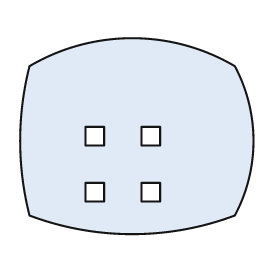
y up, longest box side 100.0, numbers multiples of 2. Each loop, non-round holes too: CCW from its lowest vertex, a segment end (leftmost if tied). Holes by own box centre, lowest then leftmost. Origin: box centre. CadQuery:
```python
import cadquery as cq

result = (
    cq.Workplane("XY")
    .moveTo(-46.0, -34.0)
    .threePointArc((-2.0, -42.0), (42.0, -34.0))
    .threePointArc((50.0, -2.0), (42.0, 30.0))
    .threePointArc((-2.0, 42.0), (-46.0, 30.0))
    .threePointArc((-50.0, -2.0), (-46.0, -34.0))
    .close()
    .moveTo(-22.0, -28.0)
    .lineTo(-14.0, -28.0)
    .lineTo(-14.0, -20.0)
    .lineTo(-22.0, -20.0)
    .close()
    .moveTo(2.0, -28.0)
    .lineTo(10.0, -28.0)
    .lineTo(10.0, -20.0)
    .lineTo(2.0, -20.0)
    .close()
    .moveTo(-22.0, -4.0)
    .lineTo(-14.0, -4.0)
    .lineTo(-14.0, 4.0)
    .lineTo(-22.0, 4.0)
    .close()
    .moveTo(2.0, -4.0)
    .lineTo(10.0, -4.0)
    .lineTo(10.0, 4.0)
    .lineTo(2.0, 4.0)
    .close()
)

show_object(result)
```